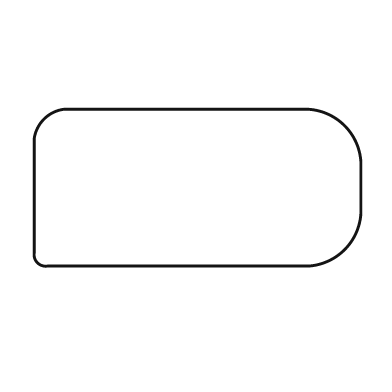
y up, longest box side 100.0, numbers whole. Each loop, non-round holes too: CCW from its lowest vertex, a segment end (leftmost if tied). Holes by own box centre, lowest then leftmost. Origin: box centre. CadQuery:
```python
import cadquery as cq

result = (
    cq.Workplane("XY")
    .moveTo(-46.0, -24.0)
    .lineTo(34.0, -24.0)
    .threePointArc((45.0, -19.0), (50.0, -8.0))
    .lineTo(50.0, 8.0)
    .threePointArc((45.0, 19.0), (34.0, 24.0))
    .lineTo(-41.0, 24.0)
    .threePointArc((-47.0, 21.0), (-50.0, 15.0))
    .lineTo(-50.0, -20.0)
    .threePointArc((-49.0, -23.0), (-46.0, -24.0))
    .close()
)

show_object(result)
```